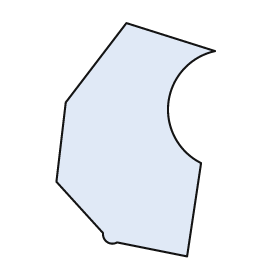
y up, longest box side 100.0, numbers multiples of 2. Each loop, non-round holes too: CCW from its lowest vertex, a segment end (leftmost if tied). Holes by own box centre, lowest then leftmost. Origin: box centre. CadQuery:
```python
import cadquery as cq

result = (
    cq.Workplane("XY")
    .moveTo(22.0, -50.0)
    .lineTo(28.0, -10.0)
    .threePointArc((14.0, 16.0), (34.0, 38.0))
    .lineTo(-4.0, 50.0)
    .lineTo(-30.0, 16.0)
    .lineTo(-34.0, -18.0)
    .lineTo(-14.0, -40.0)
    .threePointArc((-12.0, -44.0), (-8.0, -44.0))
    .close()
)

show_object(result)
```